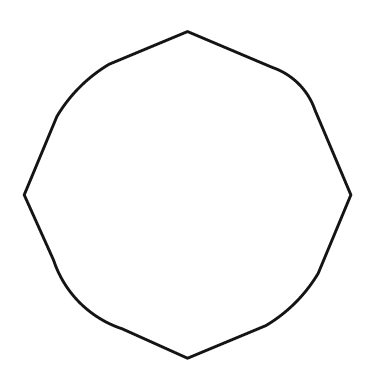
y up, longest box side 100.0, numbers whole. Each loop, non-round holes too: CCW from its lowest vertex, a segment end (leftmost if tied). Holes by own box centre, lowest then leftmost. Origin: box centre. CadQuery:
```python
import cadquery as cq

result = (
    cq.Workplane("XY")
    .moveTo(0.0, -50.0)
    .lineTo(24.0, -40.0)
    .threePointArc((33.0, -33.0), (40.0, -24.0))
    .lineTo(50.0, 0.0)
    .lineTo(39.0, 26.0)
    .threePointArc((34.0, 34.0), (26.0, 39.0))
    .lineTo(0.0, 50.0)
    .lineTo(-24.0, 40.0)
    .threePointArc((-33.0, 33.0), (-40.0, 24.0))
    .lineTo(-50.0, 0.0)
    .lineTo(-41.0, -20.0)
    .threePointArc((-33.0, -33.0), (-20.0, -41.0))
    .close()
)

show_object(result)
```